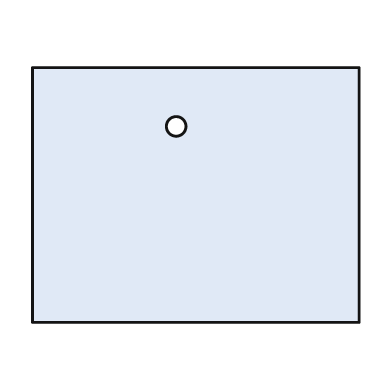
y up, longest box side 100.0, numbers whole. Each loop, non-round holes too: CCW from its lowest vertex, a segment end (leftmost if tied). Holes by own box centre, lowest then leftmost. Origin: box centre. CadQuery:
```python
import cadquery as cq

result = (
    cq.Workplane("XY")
    .moveTo(-50.0, -39.0)
    .lineTo(50.0, -39.0)
    .lineTo(50.0, 39.0)
    .lineTo(-50.0, 39.0)
    .close()
    .moveTo(-6.0, 21.0)
    .circle(3.0)
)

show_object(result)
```